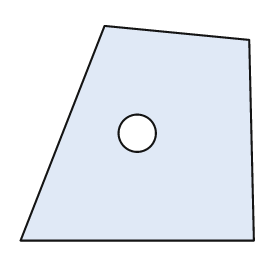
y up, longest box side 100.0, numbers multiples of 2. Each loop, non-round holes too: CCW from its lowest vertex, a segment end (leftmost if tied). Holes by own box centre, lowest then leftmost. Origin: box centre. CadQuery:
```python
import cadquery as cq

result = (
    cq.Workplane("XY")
    .moveTo(-50.0, -46.0)
    .lineTo(50.0, -46.0)
    .lineTo(48.0, 40.0)
    .lineTo(-14.0, 46.0)
    .close()
    .moveTo(0.0, 0.0)
    .circle(8.0)
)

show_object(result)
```